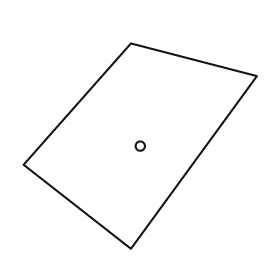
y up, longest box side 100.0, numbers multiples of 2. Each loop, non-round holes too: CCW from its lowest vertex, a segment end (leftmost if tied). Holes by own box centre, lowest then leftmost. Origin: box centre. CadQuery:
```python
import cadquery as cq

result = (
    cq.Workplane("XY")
    .moveTo(-4.0, -44.0)
    .lineTo(50.0, 30.0)
    .lineTo(-4.0, 44.0)
    .lineTo(-50.0, -8.0)
    .close()
    .moveTo(0.0, 0.0)
    .circle(2.0)
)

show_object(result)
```